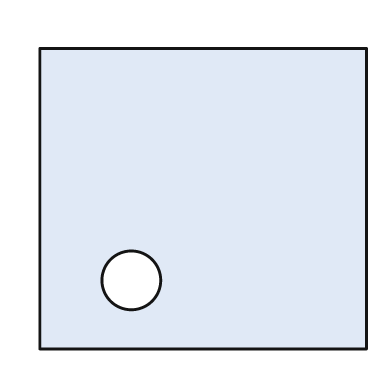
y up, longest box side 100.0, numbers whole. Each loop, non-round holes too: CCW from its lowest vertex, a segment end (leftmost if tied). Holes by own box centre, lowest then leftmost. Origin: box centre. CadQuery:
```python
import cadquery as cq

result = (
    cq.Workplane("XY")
    .moveTo(-50.0, -46.0)
    .lineTo(50.0, -46.0)
    .lineTo(50.0, 46.0)
    .lineTo(-50.0, 46.0)
    .close()
    .moveTo(-22.0, -25.0)
    .circle(9.0)
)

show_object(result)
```